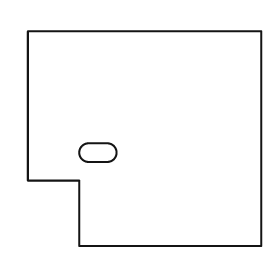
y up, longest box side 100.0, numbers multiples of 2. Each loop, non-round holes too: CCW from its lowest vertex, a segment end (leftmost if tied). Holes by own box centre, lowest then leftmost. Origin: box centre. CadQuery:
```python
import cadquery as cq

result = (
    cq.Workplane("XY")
    .moveTo(-28.0, -46.0)
    .lineTo(50.0, -46.0)
    .lineTo(50.0, 46.0)
    .lineTo(-50.0, 46.0)
    .lineTo(-50.0, -18.0)
    .lineTo(-28.0, -18.0)
    .close()
    .moveTo(-24.0, -10.0)
    .lineTo(-16.0, -10.0)
    .threePointArc((-12.0, -6.0), (-16.0, -2.0))
    .lineTo(-24.0, -2.0)
    .threePointArc((-28.0, -6.0), (-24.0, -10.0))
    .close()
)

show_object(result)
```